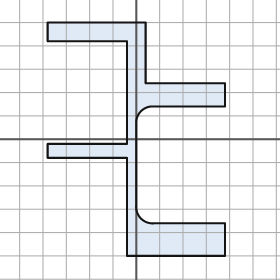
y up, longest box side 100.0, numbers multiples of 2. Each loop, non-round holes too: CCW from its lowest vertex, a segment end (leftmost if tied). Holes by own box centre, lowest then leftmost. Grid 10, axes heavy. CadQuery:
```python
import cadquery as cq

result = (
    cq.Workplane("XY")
    .moveTo(-4.0, -50.0)
    .lineTo(38.0, -50.0)
    .lineTo(38.0, -36.0)
    .lineTo(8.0, -36.0)
    .threePointArc((2.0, -34.0), (0.0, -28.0))
    .lineTo(0.0, 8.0)
    .threePointArc((2.0, 12.0), (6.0, 14.0))
    .lineTo(38.0, 14.0)
    .lineTo(38.0, 24.0)
    .lineTo(4.0, 24.0)
    .lineTo(4.0, 50.0)
    .lineTo(-38.0, 50.0)
    .lineTo(-38.0, 42.0)
    .lineTo(-4.0, 42.0)
    .lineTo(-4.0, -2.0)
    .lineTo(-38.0, -2.0)
    .lineTo(-38.0, -8.0)
    .lineTo(-4.0, -8.0)
    .close()
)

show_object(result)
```